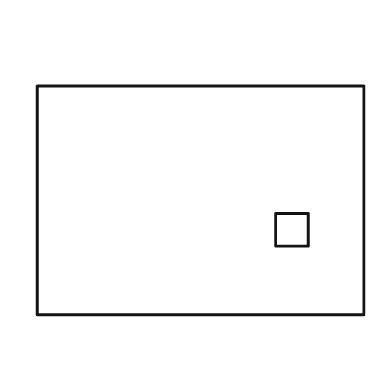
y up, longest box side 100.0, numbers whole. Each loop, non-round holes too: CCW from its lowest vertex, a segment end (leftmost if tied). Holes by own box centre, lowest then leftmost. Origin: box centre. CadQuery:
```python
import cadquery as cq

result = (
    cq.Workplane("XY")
    .moveTo(-50.0, -35.0)
    .lineTo(50.0, -35.0)
    .lineTo(50.0, 35.0)
    .lineTo(-50.0, 35.0)
    .close()
    .moveTo(23.0, -14.0)
    .lineTo(33.0, -14.0)
    .lineTo(33.0, -4.0)
    .lineTo(23.0, -4.0)
    .close()
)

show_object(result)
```